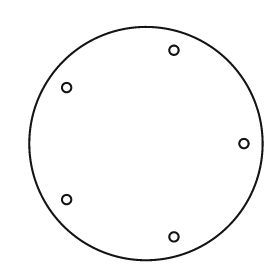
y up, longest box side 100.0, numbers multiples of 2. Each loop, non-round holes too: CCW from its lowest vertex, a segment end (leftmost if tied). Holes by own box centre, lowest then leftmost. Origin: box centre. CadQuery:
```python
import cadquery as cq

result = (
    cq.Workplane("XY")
    .moveTo(0.0, 0.0)
    .circle(50.0)
    .moveTo(12.0, -40.0)
    .circle(2.0)
    .moveTo(-34.0, -24.0)
    .circle(2.0)
    .moveTo(42.0, 0.0)
    .circle(2.0)
    .moveTo(-34.0, 24.0)
    .circle(2.0)
    .moveTo(12.0, 40.0)
    .circle(2.0)
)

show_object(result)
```